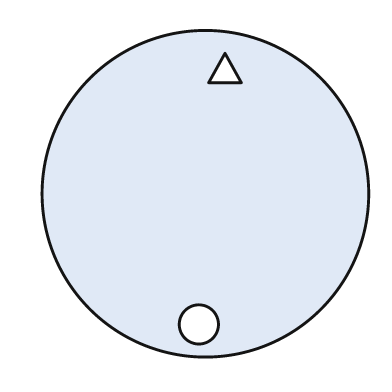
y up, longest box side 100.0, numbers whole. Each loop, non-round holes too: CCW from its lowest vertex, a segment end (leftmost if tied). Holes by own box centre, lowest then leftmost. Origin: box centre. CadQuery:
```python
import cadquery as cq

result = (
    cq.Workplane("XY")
    .moveTo(0.0, 0.0)
    .circle(50.0)
    .moveTo(-2.0, -40.0)
    .circle(6.0)
    .moveTo(1.0, 34.0)
    .lineTo(11.0, 34.0)
    .lineTo(6.0, 43.0)
    .close()
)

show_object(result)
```